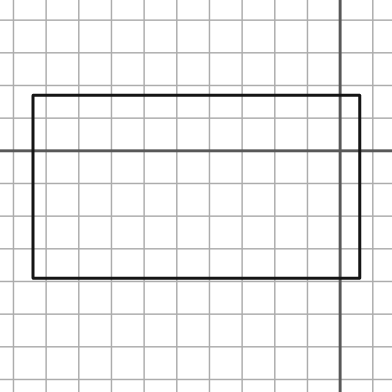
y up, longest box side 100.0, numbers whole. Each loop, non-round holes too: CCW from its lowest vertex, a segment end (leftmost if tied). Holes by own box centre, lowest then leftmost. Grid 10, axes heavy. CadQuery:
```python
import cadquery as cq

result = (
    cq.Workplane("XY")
    .moveTo(-94.0, -39.0)
    .lineTo(6.0, -39.0)
    .lineTo(6.0, 17.0)
    .lineTo(-94.0, 17.0)
    .close()
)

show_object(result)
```